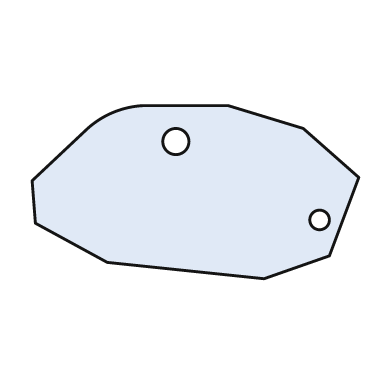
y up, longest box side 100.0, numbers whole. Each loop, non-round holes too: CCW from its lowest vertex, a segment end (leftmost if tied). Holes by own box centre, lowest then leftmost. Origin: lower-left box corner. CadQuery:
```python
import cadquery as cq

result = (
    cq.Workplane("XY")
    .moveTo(71.0, 0.0)
    .lineTo(91.0, 7.0)
    .lineTo(100.0, 31.0)
    .lineTo(83.0, 46.0)
    .lineTo(60.0, 53.0)
    .lineTo(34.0, 53.0)
    .threePointArc((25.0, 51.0), (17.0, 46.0))
    .lineTo(0.0, 30.0)
    .lineTo(1.0, 17.0)
    .lineTo(23.0, 5.0)
    .close()
    .moveTo(88.0, 18.0)
    .circle(3.0)
    .moveTo(44.0, 42.0)
    .circle(4.0)
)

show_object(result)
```